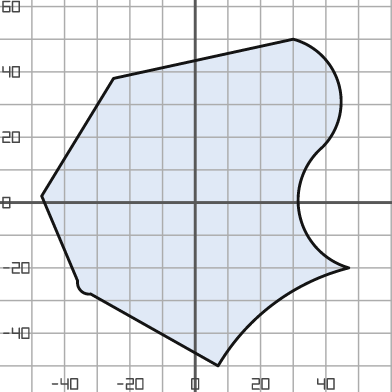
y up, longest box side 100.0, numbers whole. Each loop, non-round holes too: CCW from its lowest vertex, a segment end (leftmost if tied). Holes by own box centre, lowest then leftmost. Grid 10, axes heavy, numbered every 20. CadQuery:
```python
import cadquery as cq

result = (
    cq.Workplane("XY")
    .moveTo(7.0, -50.0)
    .threePointArc((24.0, -31.0), (47.0, -20.0))
    .threePointArc((32.0, -4.0), (39.0, 17.0))
    .threePointArc((44.0, 36.0), (30.0, 50.0))
    .lineTo(-25.0, 38.0)
    .lineTo(-47.0, 2.0)
    .lineTo(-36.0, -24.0)
    .threePointArc((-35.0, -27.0), (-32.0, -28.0))
    .close()
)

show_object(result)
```